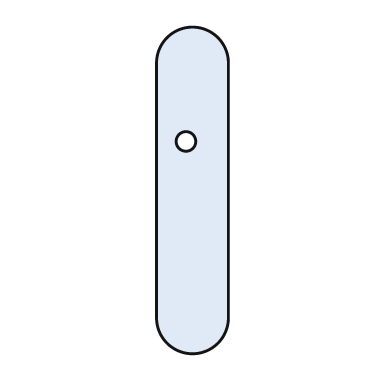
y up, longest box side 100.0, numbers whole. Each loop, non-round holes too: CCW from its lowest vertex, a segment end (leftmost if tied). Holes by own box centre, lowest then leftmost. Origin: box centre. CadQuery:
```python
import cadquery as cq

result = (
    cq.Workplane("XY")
    .moveTo(-11.0, -39.0)
    .threePointArc((0.0, -50.0), (11.0, -39.0))
    .lineTo(11.0, 39.0)
    .threePointArc((0.0, 50.0), (-11.0, 39.0))
    .close()
    .moveTo(-2.0, 15.0)
    .circle(3.0)
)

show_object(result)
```